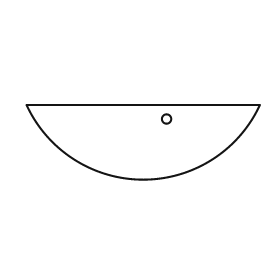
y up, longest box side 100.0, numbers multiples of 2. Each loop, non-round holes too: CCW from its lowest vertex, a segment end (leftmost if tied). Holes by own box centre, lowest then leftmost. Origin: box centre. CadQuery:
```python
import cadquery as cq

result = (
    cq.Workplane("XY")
    .moveTo(-50.0, 16.0)
    .threePointArc((0.0, -16.0), (50.0, 16.0))
    .close()
    .moveTo(10.0, 10.0)
    .circle(2.0)
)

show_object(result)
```